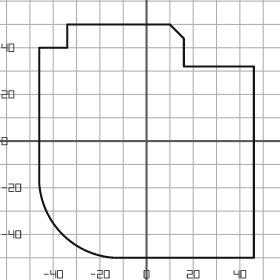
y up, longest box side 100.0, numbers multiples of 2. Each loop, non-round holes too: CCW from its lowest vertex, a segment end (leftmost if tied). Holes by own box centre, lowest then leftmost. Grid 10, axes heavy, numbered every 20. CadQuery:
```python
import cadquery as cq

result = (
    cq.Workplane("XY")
    .moveTo(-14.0, -50.0)
    .lineTo(46.0, -50.0)
    .lineTo(46.0, 32.0)
    .lineTo(16.0, 32.0)
    .lineTo(16.0, 44.0)
    .lineTo(10.0, 50.0)
    .lineTo(-34.0, 50.0)
    .lineTo(-34.0, 40.0)
    .lineTo(-46.0, 40.0)
    .lineTo(-46.0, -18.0)
    .threePointArc((-36.0, -40.0), (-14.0, -50.0))
    .close()
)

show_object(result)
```